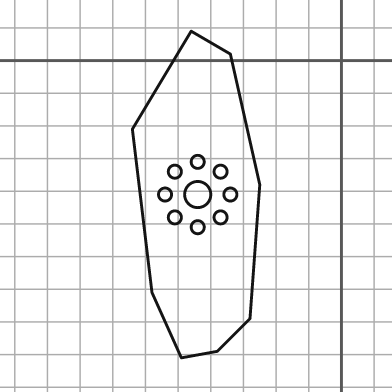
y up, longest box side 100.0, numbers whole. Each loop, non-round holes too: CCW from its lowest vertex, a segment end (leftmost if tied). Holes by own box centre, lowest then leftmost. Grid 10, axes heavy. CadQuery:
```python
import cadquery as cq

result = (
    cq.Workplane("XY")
    .moveTo(-49.0, -91.0)
    .lineTo(-38.0, -89.0)
    .lineTo(-28.0, -79.0)
    .lineTo(-25.0, -38.0)
    .lineTo(-34.0, 2.0)
    .lineTo(-46.0, 9.0)
    .lineTo(-64.0, -21.0)
    .lineTo(-58.0, -71.0)
    .close()
    .moveTo(-44.0, -51.0)
    .circle(2.0)
    .moveTo(-51.0, -48.0)
    .circle(2.0)
    .moveTo(-37.0, -48.0)
    .circle(2.0)
    .moveTo(-54.0, -41.0)
    .circle(2.0)
    .moveTo(-44.0, -41.0)
    .circle(4.0)
    .moveTo(-34.0, -41.0)
    .circle(2.0)
    .moveTo(-51.0, -34.0)
    .circle(2.0)
    .moveTo(-37.0, -34.0)
    .circle(2.0)
    .moveTo(-44.0, -31.0)
    .circle(2.0)
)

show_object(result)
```